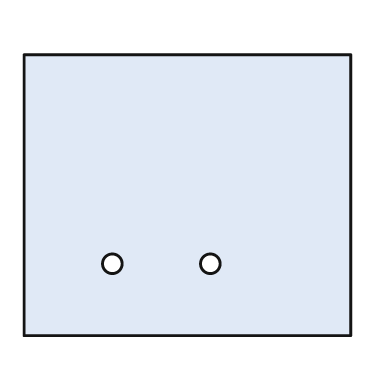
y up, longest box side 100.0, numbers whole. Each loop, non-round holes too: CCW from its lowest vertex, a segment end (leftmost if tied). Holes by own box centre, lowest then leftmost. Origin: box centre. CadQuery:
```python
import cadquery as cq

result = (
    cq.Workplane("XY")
    .moveTo(-50.0, -43.0)
    .lineTo(50.0, -43.0)
    .lineTo(50.0, 43.0)
    .lineTo(-50.0, 43.0)
    .close()
    .moveTo(-23.0, -21.0)
    .circle(3.0)
    .moveTo(7.0, -21.0)
    .circle(3.0)
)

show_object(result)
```